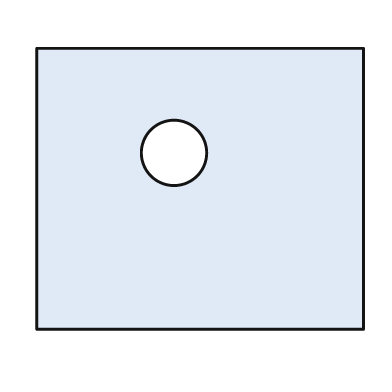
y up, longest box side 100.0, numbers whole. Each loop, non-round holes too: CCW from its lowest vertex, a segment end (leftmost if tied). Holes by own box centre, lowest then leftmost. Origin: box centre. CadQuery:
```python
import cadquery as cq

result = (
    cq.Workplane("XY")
    .moveTo(-50.0, -43.0)
    .lineTo(50.0, -43.0)
    .lineTo(50.0, 43.0)
    .lineTo(-50.0, 43.0)
    .close()
    .moveTo(-8.0, 11.0)
    .circle(10.0)
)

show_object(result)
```